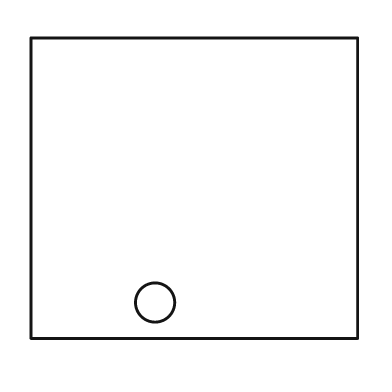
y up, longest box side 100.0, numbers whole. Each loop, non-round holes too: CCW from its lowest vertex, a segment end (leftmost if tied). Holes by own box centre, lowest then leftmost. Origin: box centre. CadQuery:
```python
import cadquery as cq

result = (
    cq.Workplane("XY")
    .moveTo(-50.0, -46.0)
    .lineTo(50.0, -46.0)
    .lineTo(50.0, 46.0)
    .lineTo(-50.0, 46.0)
    .close()
    .moveTo(-12.0, -35.0)
    .circle(6.0)
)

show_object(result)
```